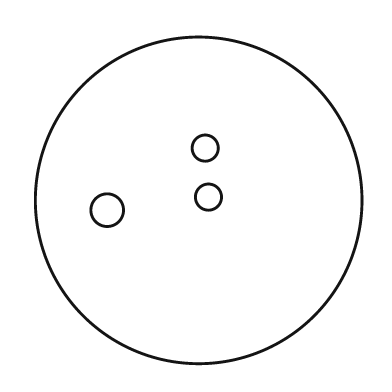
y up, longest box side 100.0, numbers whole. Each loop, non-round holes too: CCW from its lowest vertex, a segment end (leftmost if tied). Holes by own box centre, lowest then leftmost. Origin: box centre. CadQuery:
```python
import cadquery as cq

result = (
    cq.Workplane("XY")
    .moveTo(0.0, 0.0)
    .circle(50.0)
    .moveTo(-28.0, -3.0)
    .circle(5.0)
    .moveTo(3.0, 1.0)
    .circle(4.0)
    .moveTo(2.0, 16.0)
    .circle(4.0)
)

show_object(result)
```